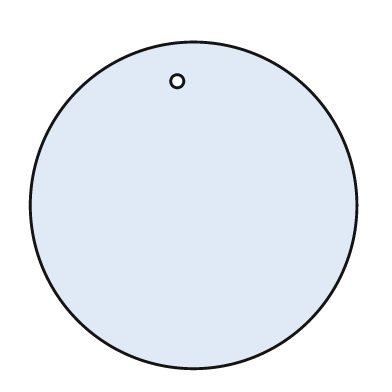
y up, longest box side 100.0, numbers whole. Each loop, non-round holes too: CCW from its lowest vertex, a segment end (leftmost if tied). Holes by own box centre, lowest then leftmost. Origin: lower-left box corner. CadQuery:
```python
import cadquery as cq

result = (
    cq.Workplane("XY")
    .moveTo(50.0, 50.0)
    .circle(50.0)
    .moveTo(45.0, 88.0)
    .circle(2.0)
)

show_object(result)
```